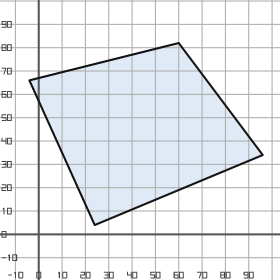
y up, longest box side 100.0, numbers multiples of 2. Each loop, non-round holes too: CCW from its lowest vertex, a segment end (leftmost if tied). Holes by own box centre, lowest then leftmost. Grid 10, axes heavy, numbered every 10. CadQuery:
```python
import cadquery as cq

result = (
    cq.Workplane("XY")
    .moveTo(24.0, 4.0)
    .lineTo(96.0, 34.0)
    .lineTo(60.0, 82.0)
    .lineTo(-4.0, 66.0)
    .close()
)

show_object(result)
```